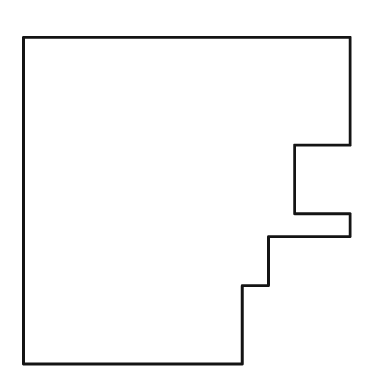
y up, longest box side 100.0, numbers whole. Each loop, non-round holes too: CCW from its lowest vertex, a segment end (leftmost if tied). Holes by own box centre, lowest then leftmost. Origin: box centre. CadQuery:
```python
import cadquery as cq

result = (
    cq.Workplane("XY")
    .moveTo(-50.0, -50.0)
    .lineTo(17.0, -50.0)
    .lineTo(17.0, -26.0)
    .lineTo(25.0, -26.0)
    .lineTo(25.0, -11.0)
    .lineTo(50.0, -11.0)
    .lineTo(50.0, -4.0)
    .lineTo(33.0, -4.0)
    .lineTo(33.0, 17.0)
    .lineTo(50.0, 17.0)
    .lineTo(50.0, 50.0)
    .lineTo(-50.0, 50.0)
    .close()
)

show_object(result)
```